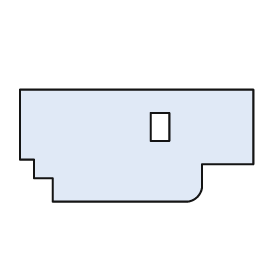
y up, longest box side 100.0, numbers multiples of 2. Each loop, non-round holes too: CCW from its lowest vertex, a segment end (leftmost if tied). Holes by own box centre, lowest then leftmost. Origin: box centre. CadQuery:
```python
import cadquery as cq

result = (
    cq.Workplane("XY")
    .moveTo(-36.0, -24.0)
    .lineTo(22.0, -24.0)
    .threePointArc((26.0, -22.0), (28.0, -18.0))
    .lineTo(28.0, -8.0)
    .lineTo(50.0, -8.0)
    .lineTo(50.0, 24.0)
    .lineTo(-50.0, 24.0)
    .lineTo(-50.0, -6.0)
    .lineTo(-44.0, -6.0)
    .lineTo(-44.0, -14.0)
    .lineTo(-36.0, -14.0)
    .close()
    .moveTo(6.0, 2.0)
    .lineTo(14.0, 2.0)
    .lineTo(14.0, 14.0)
    .lineTo(6.0, 14.0)
    .close()
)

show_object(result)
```